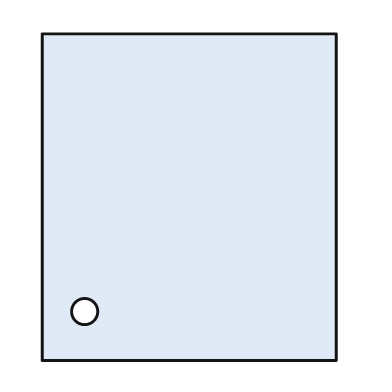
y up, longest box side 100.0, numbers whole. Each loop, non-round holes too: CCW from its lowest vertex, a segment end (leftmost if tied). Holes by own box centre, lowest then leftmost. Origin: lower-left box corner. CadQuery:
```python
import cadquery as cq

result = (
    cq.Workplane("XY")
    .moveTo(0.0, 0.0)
    .lineTo(90.0, 0.0)
    .lineTo(90.0, 100.0)
    .lineTo(0.0, 100.0)
    .close()
    .moveTo(13.0, 15.0)
    .circle(4.0)
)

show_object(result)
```